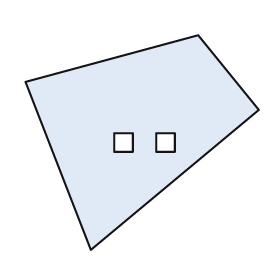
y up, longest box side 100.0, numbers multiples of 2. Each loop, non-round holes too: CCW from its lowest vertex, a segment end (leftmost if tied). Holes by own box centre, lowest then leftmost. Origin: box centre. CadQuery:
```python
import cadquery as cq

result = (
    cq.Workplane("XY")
    .moveTo(-22.0, -46.0)
    .lineTo(50.0, 14.0)
    .lineTo(24.0, 46.0)
    .lineTo(-50.0, 26.0)
    .close()
    .moveTo(-12.0, -4.0)
    .lineTo(-4.0, -4.0)
    .lineTo(-4.0, 4.0)
    .lineTo(-12.0, 4.0)
    .close()
    .moveTo(6.0, -4.0)
    .lineTo(14.0, -4.0)
    .lineTo(14.0, 4.0)
    .lineTo(6.0, 4.0)
    .close()
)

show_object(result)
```